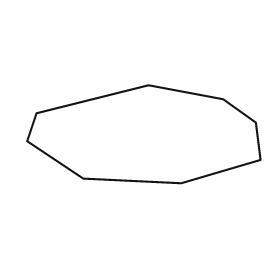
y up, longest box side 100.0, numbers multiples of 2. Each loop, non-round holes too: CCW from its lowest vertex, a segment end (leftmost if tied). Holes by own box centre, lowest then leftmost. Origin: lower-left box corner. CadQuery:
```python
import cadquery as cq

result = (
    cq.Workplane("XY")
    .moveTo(66.0, 0.0)
    .lineTo(100.0, 10.0)
    .lineTo(98.0, 26.0)
    .lineTo(84.0, 36.0)
    .lineTo(52.0, 42.0)
    .lineTo(4.0, 30.0)
    .lineTo(0.0, 18.0)
    .lineTo(24.0, 2.0)
    .close()
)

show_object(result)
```